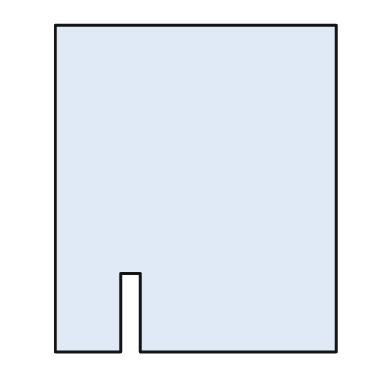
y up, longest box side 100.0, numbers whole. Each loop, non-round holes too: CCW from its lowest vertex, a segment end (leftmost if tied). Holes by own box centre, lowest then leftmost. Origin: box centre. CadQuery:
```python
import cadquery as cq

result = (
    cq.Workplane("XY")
    .moveTo(-43.0, -50.0)
    .lineTo(-23.0, -50.0)
    .lineTo(-23.0, -26.0)
    .lineTo(-17.0, -26.0)
    .lineTo(-17.0, -50.0)
    .lineTo(43.0, -50.0)
    .lineTo(43.0, 50.0)
    .lineTo(-43.0, 50.0)
    .close()
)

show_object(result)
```